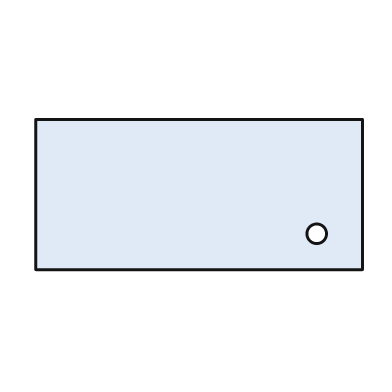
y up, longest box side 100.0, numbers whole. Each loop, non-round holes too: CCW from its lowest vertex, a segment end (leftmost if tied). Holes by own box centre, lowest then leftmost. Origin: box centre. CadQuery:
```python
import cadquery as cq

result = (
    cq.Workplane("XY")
    .moveTo(-50.0, -23.0)
    .lineTo(50.0, -23.0)
    .lineTo(50.0, 23.0)
    .lineTo(-50.0, 23.0)
    .close()
    .moveTo(36.0, -12.0)
    .circle(3.0)
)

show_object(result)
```